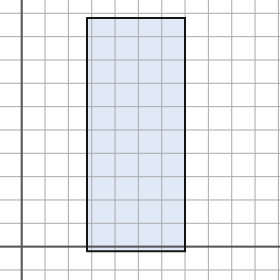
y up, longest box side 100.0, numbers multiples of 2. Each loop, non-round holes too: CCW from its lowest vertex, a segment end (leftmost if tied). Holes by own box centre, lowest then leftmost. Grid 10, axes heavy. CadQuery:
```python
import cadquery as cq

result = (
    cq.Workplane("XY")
    .moveTo(28.0, -2.0)
    .lineTo(70.0, -2.0)
    .lineTo(70.0, 98.0)
    .lineTo(28.0, 98.0)
    .close()
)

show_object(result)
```